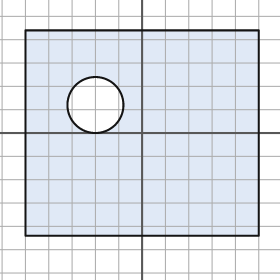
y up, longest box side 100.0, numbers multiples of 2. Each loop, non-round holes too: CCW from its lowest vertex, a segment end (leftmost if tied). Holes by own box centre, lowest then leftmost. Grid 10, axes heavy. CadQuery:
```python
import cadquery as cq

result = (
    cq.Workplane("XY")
    .moveTo(-50.0, -44.0)
    .lineTo(50.0, -44.0)
    .lineTo(50.0, 44.0)
    .lineTo(-50.0, 44.0)
    .close()
    .moveTo(-20.0, 12.0)
    .circle(12.0)
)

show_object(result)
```